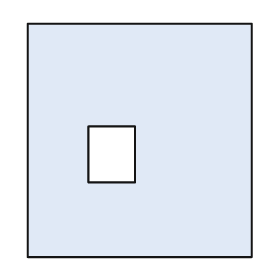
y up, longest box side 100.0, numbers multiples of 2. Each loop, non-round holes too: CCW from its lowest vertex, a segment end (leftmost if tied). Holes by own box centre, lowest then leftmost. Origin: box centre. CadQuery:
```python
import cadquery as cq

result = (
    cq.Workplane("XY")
    .moveTo(-48.0, -50.0)
    .lineTo(48.0, -50.0)
    .lineTo(48.0, 50.0)
    .lineTo(-48.0, 50.0)
    .close()
    .moveTo(-22.0, -18.0)
    .lineTo(-2.0, -18.0)
    .lineTo(-2.0, 6.0)
    .lineTo(-22.0, 6.0)
    .close()
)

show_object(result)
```